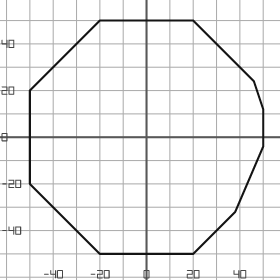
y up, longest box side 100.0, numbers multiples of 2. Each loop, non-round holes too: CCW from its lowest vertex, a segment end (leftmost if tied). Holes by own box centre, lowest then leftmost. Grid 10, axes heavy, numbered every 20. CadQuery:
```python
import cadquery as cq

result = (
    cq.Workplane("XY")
    .moveTo(-20.0, -50.0)
    .lineTo(20.0, -50.0)
    .lineTo(38.0, -32.0)
    .lineTo(50.0, -4.0)
    .lineTo(50.0, 12.0)
    .lineTo(46.0, 24.0)
    .lineTo(20.0, 50.0)
    .lineTo(-20.0, 50.0)
    .lineTo(-50.0, 20.0)
    .lineTo(-50.0, -20.0)
    .close()
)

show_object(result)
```